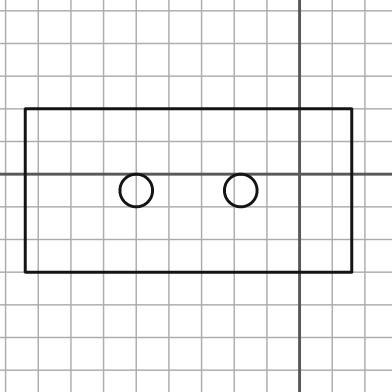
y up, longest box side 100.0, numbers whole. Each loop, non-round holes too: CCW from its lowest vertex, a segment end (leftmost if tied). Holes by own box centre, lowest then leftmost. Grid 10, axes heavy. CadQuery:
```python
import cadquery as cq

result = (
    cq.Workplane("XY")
    .moveTo(-84.0, -30.0)
    .lineTo(16.0, -30.0)
    .lineTo(16.0, 20.0)
    .lineTo(-84.0, 20.0)
    .close()
    .moveTo(-50.0, -5.0)
    .circle(5.0)
    .moveTo(-18.0, -5.0)
    .circle(5.0)
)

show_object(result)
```